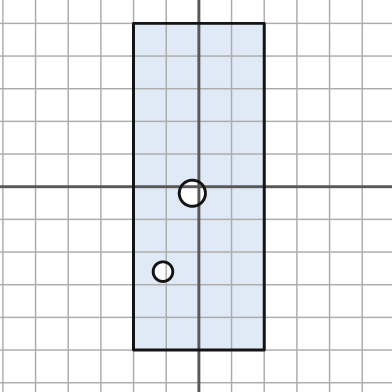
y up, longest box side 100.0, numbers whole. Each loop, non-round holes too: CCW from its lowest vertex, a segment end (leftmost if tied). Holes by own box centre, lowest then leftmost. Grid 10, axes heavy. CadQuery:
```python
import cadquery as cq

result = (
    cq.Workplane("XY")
    .moveTo(-20.0, -50.0)
    .lineTo(20.0, -50.0)
    .lineTo(20.0, 50.0)
    .lineTo(-20.0, 50.0)
    .close()
    .moveTo(-11.0, -26.0)
    .circle(3.0)
    .moveTo(-2.0, -2.0)
    .circle(4.0)
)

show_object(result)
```